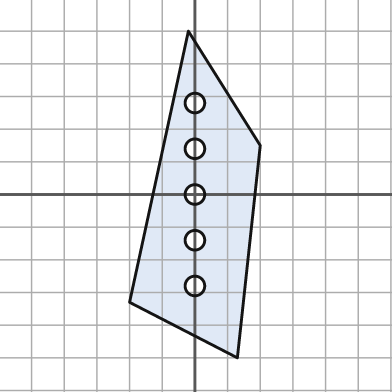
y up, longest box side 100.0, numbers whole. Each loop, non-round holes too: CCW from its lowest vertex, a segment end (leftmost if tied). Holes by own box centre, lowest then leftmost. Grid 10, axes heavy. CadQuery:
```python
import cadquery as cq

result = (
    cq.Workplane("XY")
    .moveTo(13.0, -50.0)
    .lineTo(20.0, 15.0)
    .lineTo(-2.0, 50.0)
    .lineTo(-20.0, -33.0)
    .close()
    .moveTo(0.0, -28.0)
    .circle(3.0)
    .moveTo(0.0, -14.0)
    .circle(3.0)
    .moveTo(0.0, 0.0)
    .circle(3.0)
    .moveTo(0.0, 14.0)
    .circle(3.0)
    .moveTo(0.0, 28.0)
    .circle(3.0)
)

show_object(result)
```